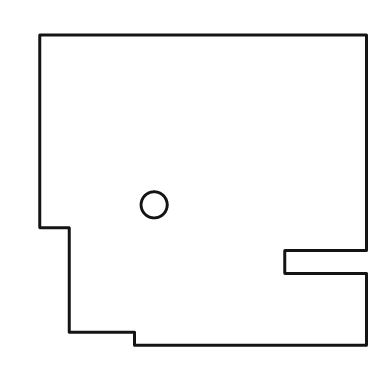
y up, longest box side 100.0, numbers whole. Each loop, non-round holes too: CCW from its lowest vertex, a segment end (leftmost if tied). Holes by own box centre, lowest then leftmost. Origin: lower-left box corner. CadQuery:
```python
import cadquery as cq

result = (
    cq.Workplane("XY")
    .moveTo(29.0, 0.0)
    .lineTo(100.0, 0.0)
    .lineTo(100.0, 22.0)
    .lineTo(75.0, 22.0)
    .lineTo(75.0, 29.0)
    .lineTo(100.0, 29.0)
    .lineTo(100.0, 95.0)
    .lineTo(0.0, 95.0)
    .lineTo(0.0, 36.0)
    .lineTo(9.0, 36.0)
    .lineTo(9.0, 4.0)
    .lineTo(29.0, 4.0)
    .close()
    .moveTo(35.0, 43.0)
    .circle(4.0)
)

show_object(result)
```